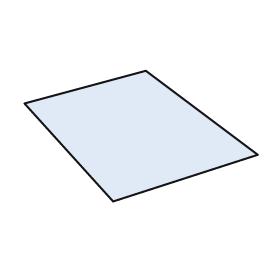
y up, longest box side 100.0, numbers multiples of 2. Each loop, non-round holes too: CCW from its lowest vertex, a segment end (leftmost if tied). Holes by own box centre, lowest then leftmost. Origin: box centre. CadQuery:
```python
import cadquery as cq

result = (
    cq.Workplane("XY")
    .moveTo(-12.0, -28.0)
    .lineTo(50.0, -8.0)
    .lineTo(2.0, 28.0)
    .lineTo(-50.0, 14.0)
    .close()
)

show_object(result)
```